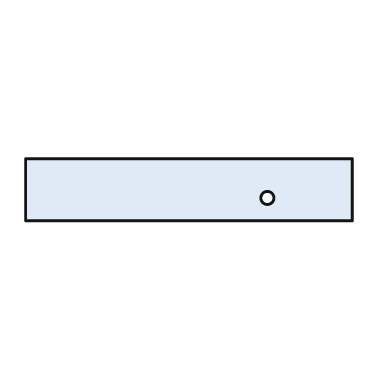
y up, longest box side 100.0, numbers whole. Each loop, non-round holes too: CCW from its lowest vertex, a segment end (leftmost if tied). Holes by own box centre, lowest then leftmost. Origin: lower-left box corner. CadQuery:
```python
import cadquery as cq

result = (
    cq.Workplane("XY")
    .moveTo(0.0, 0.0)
    .lineTo(100.0, 0.0)
    .lineTo(100.0, 19.0)
    .lineTo(0.0, 19.0)
    .close()
    .moveTo(74.0, 7.0)
    .circle(2.0)
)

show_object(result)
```